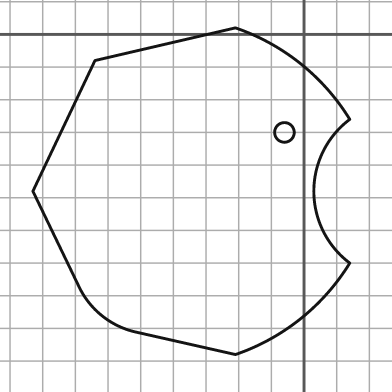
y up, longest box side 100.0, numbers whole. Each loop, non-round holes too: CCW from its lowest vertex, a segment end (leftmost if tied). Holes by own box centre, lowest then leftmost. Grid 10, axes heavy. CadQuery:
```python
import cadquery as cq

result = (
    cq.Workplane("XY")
    .moveTo(-21.0, -98.0)
    .threePointArc((-1.0, -87.0), (14.0, -70.0))
    .threePointArc((3.0, -48.0), (14.0, -26.0))
    .threePointArc((-1.0, -9.0), (-21.0, 2.0))
    .lineTo(-64.0, -8.0)
    .lineTo(-83.0, -48.0)
    .lineTo(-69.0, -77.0)
    .threePointArc((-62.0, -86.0), (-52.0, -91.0))
    .close()
    .moveTo(-6.0, -30.0)
    .circle(3.0)
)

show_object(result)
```